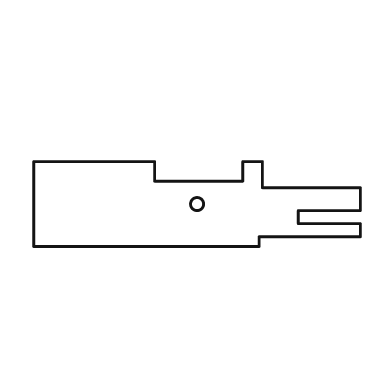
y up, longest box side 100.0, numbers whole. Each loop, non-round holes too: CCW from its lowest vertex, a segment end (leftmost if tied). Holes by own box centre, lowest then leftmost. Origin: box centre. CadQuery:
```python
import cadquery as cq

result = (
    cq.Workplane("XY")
    .moveTo(-50.0, -13.0)
    .lineTo(19.0, -13.0)
    .lineTo(19.0, -10.0)
    .lineTo(50.0, -10.0)
    .lineTo(50.0, -6.0)
    .lineTo(31.0, -6.0)
    .lineTo(31.0, -2.0)
    .lineTo(50.0, -2.0)
    .lineTo(50.0, 5.0)
    .lineTo(20.0, 5.0)
    .lineTo(20.0, 13.0)
    .lineTo(14.0, 13.0)
    .lineTo(14.0, 7.0)
    .lineTo(-13.0, 7.0)
    .lineTo(-13.0, 13.0)
    .lineTo(-50.0, 13.0)
    .close()
    .moveTo(0.0, 0.0)
    .circle(2.0)
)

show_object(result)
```